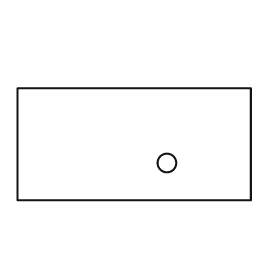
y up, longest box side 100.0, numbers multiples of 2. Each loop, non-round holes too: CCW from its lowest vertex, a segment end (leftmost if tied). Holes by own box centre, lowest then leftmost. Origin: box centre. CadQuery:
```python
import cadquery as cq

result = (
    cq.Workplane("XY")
    .moveTo(-50.0, -24.0)
    .lineTo(50.0, -24.0)
    .lineTo(50.0, 24.0)
    .lineTo(-50.0, 24.0)
    .close()
    .moveTo(14.0, -8.0)
    .circle(4.0)
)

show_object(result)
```